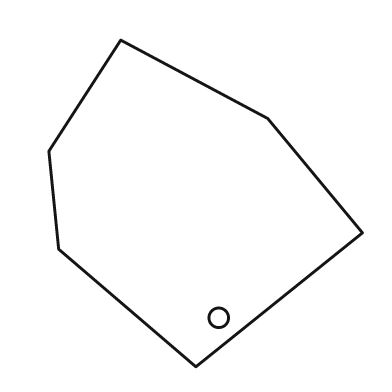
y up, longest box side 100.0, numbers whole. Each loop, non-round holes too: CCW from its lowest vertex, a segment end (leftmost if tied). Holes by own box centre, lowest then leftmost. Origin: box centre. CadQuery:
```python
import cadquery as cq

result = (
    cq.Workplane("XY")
    .moveTo(-3.0, -50.0)
    .lineTo(48.0, -9.0)
    .lineTo(19.0, 26.0)
    .lineTo(-26.0, 50.0)
    .lineTo(-48.0, 16.0)
    .lineTo(-45.0, -14.0)
    .close()
    .moveTo(4.0, -35.0)
    .circle(3.0)
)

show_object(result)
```